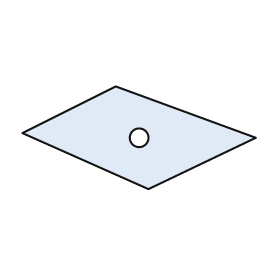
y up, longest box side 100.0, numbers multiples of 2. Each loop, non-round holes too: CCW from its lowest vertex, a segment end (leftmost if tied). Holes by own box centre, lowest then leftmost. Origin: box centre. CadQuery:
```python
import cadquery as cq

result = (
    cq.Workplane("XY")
    .moveTo(4.0, -22.0)
    .lineTo(50.0, 0.0)
    .lineTo(-10.0, 22.0)
    .lineTo(-50.0, 2.0)
    .close()
    .moveTo(0.0, 0.0)
    .circle(4.0)
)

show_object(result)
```